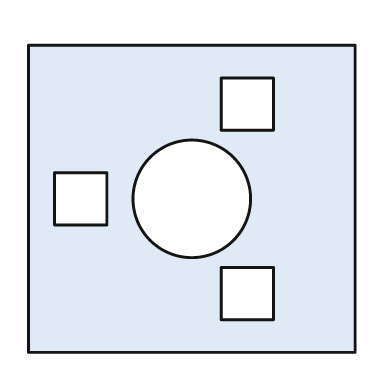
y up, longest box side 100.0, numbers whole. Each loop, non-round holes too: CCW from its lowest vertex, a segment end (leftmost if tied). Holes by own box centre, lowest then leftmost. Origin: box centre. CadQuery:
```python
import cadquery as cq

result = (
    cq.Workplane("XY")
    .moveTo(-50.0, -47.0)
    .lineTo(50.0, -47.0)
    .lineTo(50.0, 47.0)
    .lineTo(-50.0, 47.0)
    .close()
    .moveTo(9.0, -37.0)
    .lineTo(25.0, -37.0)
    .lineTo(25.0, -21.0)
    .lineTo(9.0, -21.0)
    .close()
    .moveTo(-42.0, -8.0)
    .lineTo(-26.0, -8.0)
    .lineTo(-26.0, 8.0)
    .lineTo(-42.0, 8.0)
    .close()
    .moveTo(0.0, 0.0)
    .circle(18.0)
    .moveTo(9.0, 21.0)
    .lineTo(25.0, 21.0)
    .lineTo(25.0, 37.0)
    .lineTo(9.0, 37.0)
    .close()
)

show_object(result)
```